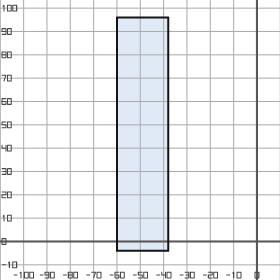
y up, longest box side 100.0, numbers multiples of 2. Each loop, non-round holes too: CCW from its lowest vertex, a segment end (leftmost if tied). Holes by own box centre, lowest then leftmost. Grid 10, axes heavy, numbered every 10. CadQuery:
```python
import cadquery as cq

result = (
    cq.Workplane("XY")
    .moveTo(-60.0, -4.0)
    .lineTo(-38.0, -4.0)
    .lineTo(-38.0, 96.0)
    .lineTo(-60.0, 96.0)
    .close()
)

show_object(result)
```